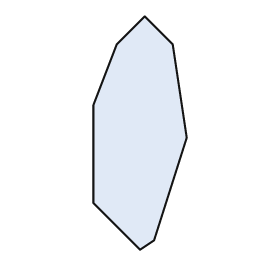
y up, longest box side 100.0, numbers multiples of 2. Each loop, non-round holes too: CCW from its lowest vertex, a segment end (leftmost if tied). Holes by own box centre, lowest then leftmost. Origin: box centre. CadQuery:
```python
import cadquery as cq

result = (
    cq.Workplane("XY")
    .moveTo(0.0, -50.0)
    .lineTo(6.0, -46.0)
    .lineTo(20.0, -2.0)
    .lineTo(14.0, 38.0)
    .lineTo(2.0, 50.0)
    .lineTo(-10.0, 38.0)
    .lineTo(-20.0, 12.0)
    .lineTo(-20.0, -30.0)
    .close()
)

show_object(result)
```